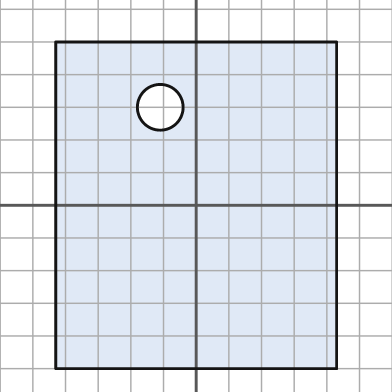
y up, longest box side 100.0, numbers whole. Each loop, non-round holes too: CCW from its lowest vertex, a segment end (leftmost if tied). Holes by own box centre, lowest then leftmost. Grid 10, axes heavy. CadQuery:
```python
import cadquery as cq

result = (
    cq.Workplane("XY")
    .moveTo(-43.0, -50.0)
    .lineTo(43.0, -50.0)
    .lineTo(43.0, 50.0)
    .lineTo(-43.0, 50.0)
    .close()
    .moveTo(-11.0, 30.0)
    .circle(7.0)
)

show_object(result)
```